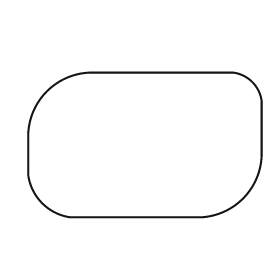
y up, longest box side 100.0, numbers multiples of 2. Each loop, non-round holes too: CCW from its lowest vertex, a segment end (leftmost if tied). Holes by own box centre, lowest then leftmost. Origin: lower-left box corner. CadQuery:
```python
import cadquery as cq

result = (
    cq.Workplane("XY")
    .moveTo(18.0, 0.0)
    .lineTo(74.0, 0.0)
    .threePointArc((92.0, 8.0), (100.0, 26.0))
    .lineTo(100.0, 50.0)
    .threePointArc((96.0, 58.0), (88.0, 62.0))
    .lineTo(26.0, 62.0)
    .threePointArc((8.0, 54.0), (0.0, 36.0))
    .lineTo(0.0, 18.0)
    .threePointArc((6.0, 6.0), (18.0, 0.0))
    .close()
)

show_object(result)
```